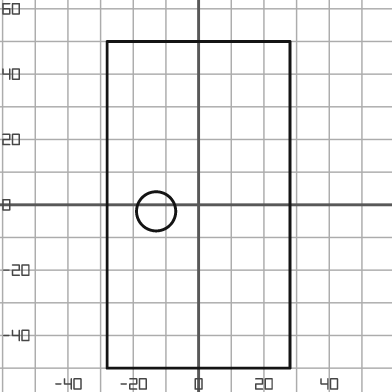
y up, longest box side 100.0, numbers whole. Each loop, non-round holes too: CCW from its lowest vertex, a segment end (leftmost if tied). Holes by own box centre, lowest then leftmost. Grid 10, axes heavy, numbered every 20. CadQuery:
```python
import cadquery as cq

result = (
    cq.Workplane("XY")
    .moveTo(-28.0, -50.0)
    .lineTo(28.0, -50.0)
    .lineTo(28.0, 50.0)
    .lineTo(-28.0, 50.0)
    .close()
    .moveTo(-13.0, -2.0)
    .circle(6.0)
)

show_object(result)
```